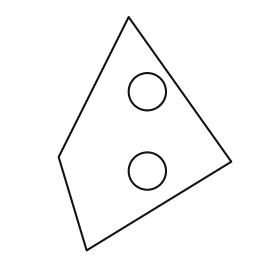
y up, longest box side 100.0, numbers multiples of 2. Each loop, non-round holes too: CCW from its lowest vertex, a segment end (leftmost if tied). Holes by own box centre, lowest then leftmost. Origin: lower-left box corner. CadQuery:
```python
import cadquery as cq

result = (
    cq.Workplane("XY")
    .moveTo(12.0, 0.0)
    .lineTo(74.0, 38.0)
    .lineTo(30.0, 100.0)
    .lineTo(0.0, 40.0)
    .close()
    .moveTo(38.0, 34.0)
    .circle(8.0)
    .moveTo(38.0, 68.0)
    .circle(8.0)
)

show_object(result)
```